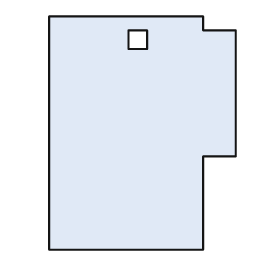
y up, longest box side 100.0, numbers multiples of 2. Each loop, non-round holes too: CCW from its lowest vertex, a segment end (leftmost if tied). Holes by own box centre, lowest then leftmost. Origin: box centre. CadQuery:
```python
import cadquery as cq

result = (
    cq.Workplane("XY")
    .moveTo(-40.0, -50.0)
    .lineTo(26.0, -50.0)
    .lineTo(26.0, -10.0)
    .lineTo(40.0, -10.0)
    .lineTo(40.0, 44.0)
    .lineTo(26.0, 44.0)
    .lineTo(26.0, 50.0)
    .lineTo(-40.0, 50.0)
    .close()
    .moveTo(-6.0, 36.0)
    .lineTo(2.0, 36.0)
    .lineTo(2.0, 44.0)
    .lineTo(-6.0, 44.0)
    .close()
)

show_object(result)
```